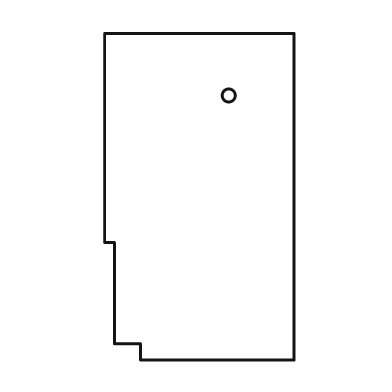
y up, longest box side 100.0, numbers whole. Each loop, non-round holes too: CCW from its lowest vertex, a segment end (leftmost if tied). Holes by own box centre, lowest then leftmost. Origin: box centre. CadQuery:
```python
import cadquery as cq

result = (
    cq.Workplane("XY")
    .moveTo(-18.0, -50.0)
    .lineTo(29.0, -50.0)
    .lineTo(29.0, 50.0)
    .lineTo(-29.0, 50.0)
    .lineTo(-29.0, -14.0)
    .lineTo(-26.0, -14.0)
    .lineTo(-26.0, -45.0)
    .lineTo(-18.0, -45.0)
    .close()
    .moveTo(9.0, 31.0)
    .circle(2.0)
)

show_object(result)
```